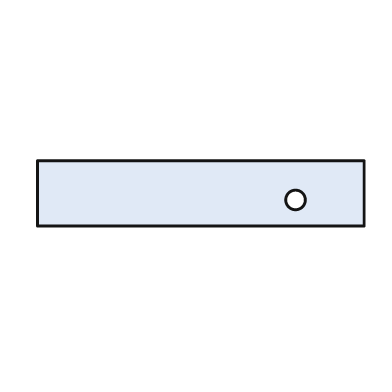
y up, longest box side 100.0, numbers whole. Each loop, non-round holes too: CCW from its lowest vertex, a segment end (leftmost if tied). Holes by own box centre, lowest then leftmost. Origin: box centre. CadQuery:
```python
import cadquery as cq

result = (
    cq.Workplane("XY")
    .moveTo(-50.0, -10.0)
    .lineTo(50.0, -10.0)
    .lineTo(50.0, 10.0)
    .lineTo(-50.0, 10.0)
    .close()
    .moveTo(29.0, -2.0)
    .circle(3.0)
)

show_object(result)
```